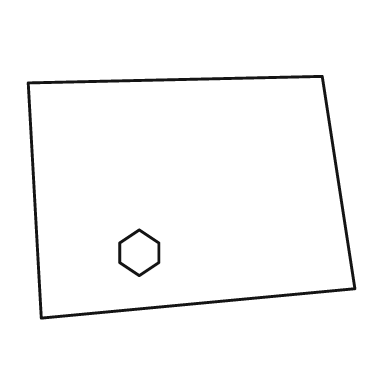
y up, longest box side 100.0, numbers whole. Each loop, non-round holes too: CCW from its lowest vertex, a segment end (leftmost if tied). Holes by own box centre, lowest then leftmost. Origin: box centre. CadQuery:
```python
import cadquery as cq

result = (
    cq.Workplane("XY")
    .moveTo(-46.0, -37.0)
    .lineTo(50.0, -28.0)
    .lineTo(40.0, 37.0)
    .lineTo(-50.0, 35.0)
    .close()
    .moveTo(-16.0, -24.0)
    .lineTo(-10.0, -20.0)
    .lineTo(-10.0, -14.0)
    .lineTo(-16.0, -10.0)
    .lineTo(-22.0, -14.0)
    .lineTo(-22.0, -20.0)
    .close()
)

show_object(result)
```